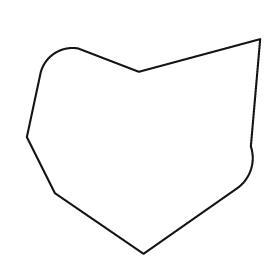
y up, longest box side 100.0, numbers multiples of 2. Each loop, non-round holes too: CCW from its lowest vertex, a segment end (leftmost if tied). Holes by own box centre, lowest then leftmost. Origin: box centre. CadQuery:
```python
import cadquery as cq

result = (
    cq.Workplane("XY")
    .moveTo(0.0, -46.0)
    .lineTo(40.0, -18.0)
    .threePointArc((46.0, -10.0), (46.0, 0.0))
    .lineTo(50.0, 46.0)
    .lineTo(-2.0, 32.0)
    .lineTo(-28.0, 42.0)
    .threePointArc((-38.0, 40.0), (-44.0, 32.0))
    .lineTo(-50.0, 4.0)
    .lineTo(-38.0, -20.0)
    .close()
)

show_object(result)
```